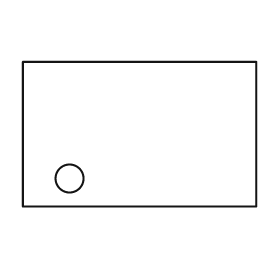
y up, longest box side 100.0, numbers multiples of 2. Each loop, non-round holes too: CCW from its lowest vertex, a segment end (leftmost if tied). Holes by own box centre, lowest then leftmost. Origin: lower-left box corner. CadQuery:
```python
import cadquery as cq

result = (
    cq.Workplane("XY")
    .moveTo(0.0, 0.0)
    .lineTo(100.0, 0.0)
    .lineTo(100.0, 62.0)
    .lineTo(0.0, 62.0)
    .close()
    .moveTo(20.0, 12.0)
    .circle(6.0)
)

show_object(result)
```